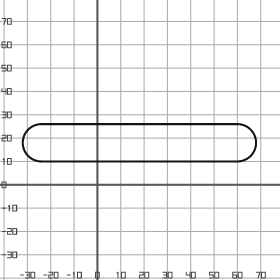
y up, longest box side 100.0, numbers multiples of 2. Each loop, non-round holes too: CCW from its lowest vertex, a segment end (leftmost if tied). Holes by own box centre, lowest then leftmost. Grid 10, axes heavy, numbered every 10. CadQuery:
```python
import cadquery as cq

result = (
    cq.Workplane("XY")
    .moveTo(-24.0, 10.0)
    .lineTo(60.0, 10.0)
    .threePointArc((68.0, 18.0), (60.0, 26.0))
    .lineTo(-24.0, 26.0)
    .threePointArc((-32.0, 18.0), (-24.0, 10.0))
    .close()
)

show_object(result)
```